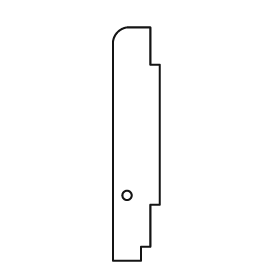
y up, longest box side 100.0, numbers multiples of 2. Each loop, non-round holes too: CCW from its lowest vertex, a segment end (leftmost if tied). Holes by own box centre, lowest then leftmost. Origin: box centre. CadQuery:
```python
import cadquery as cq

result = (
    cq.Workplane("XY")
    .moveTo(-10.0, -50.0)
    .lineTo(2.0, -50.0)
    .lineTo(2.0, -44.0)
    .lineTo(6.0, -44.0)
    .lineTo(6.0, -26.0)
    .lineTo(10.0, -26.0)
    .lineTo(10.0, 34.0)
    .lineTo(6.0, 34.0)
    .lineTo(6.0, 50.0)
    .lineTo(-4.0, 50.0)
    .threePointArc((-8.0, 48.0), (-10.0, 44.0))
    .close()
    .moveTo(-4.0, -22.0)
    .circle(2.0)
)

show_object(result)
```